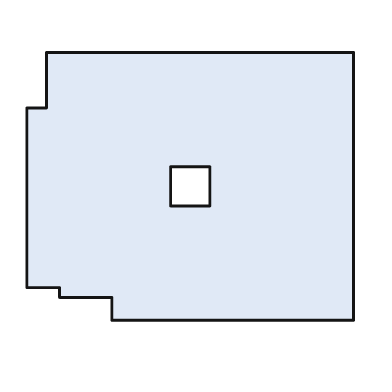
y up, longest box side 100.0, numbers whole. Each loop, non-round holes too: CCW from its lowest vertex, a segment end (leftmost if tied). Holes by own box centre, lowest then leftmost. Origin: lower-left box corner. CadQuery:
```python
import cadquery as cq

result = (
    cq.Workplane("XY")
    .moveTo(26.0, 0.0)
    .lineTo(100.0, 0.0)
    .lineTo(100.0, 82.0)
    .lineTo(6.0, 82.0)
    .lineTo(6.0, 65.0)
    .lineTo(0.0, 65.0)
    .lineTo(0.0, 10.0)
    .lineTo(10.0, 10.0)
    .lineTo(10.0, 7.0)
    .lineTo(26.0, 7.0)
    .close()
    .moveTo(44.0, 35.0)
    .lineTo(56.0, 35.0)
    .lineTo(56.0, 47.0)
    .lineTo(44.0, 47.0)
    .close()
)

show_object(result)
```